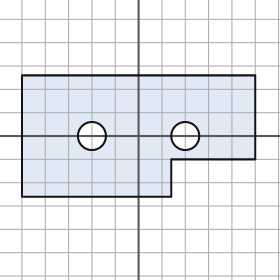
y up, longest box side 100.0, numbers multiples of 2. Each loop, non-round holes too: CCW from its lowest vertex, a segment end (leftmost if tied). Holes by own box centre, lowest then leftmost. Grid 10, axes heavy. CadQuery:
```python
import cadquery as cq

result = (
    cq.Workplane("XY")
    .moveTo(-50.0, -26.0)
    .lineTo(14.0, -26.0)
    .lineTo(14.0, -10.0)
    .lineTo(50.0, -10.0)
    .lineTo(50.0, 26.0)
    .lineTo(-50.0, 26.0)
    .close()
    .moveTo(-20.0, 0.0)
    .circle(6.0)
    .moveTo(20.0, 0.0)
    .circle(6.0)
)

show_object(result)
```